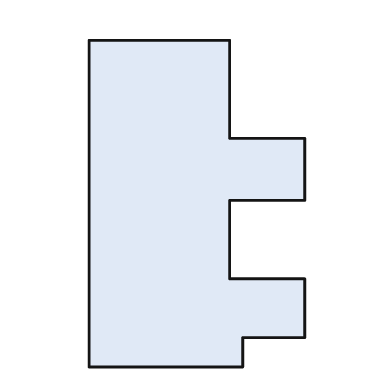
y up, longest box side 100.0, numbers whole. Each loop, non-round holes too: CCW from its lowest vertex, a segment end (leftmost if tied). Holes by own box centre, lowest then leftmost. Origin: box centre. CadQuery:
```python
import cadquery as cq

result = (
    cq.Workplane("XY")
    .moveTo(-33.0, -50.0)
    .lineTo(14.0, -50.0)
    .lineTo(14.0, -41.0)
    .lineTo(33.0, -41.0)
    .lineTo(33.0, -23.0)
    .lineTo(10.0, -23.0)
    .lineTo(10.0, 1.0)
    .lineTo(33.0, 1.0)
    .lineTo(33.0, 20.0)
    .lineTo(10.0, 20.0)
    .lineTo(10.0, 50.0)
    .lineTo(-33.0, 50.0)
    .close()
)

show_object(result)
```